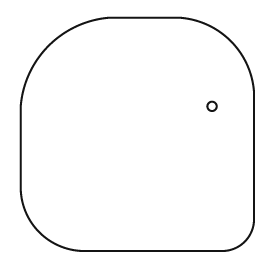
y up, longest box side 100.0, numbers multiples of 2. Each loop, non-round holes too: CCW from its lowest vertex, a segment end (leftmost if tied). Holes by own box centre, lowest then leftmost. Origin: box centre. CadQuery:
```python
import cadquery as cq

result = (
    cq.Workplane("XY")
    .moveTo(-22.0, -50.0)
    .lineTo(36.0, -50.0)
    .threePointArc((46.0, -46.0), (50.0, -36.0))
    .lineTo(50.0, 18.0)
    .threePointArc((40.0, 40.0), (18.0, 50.0))
    .lineTo(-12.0, 50.0)
    .threePointArc((-38.0, 38.0), (-50.0, 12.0))
    .lineTo(-50.0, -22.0)
    .threePointArc((-42.0, -42.0), (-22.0, -50.0))
    .close()
    .moveTo(32.0, 12.0)
    .circle(2.0)
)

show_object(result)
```